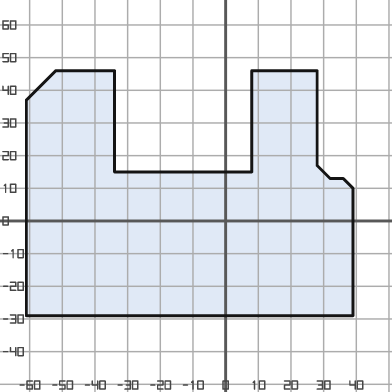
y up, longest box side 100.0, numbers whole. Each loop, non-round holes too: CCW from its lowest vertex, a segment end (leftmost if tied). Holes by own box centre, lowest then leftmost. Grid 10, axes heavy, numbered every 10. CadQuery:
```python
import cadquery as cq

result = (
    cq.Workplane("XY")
    .moveTo(-61.0, -29.0)
    .lineTo(39.0, -29.0)
    .lineTo(39.0, 10.0)
    .lineTo(36.0, 13.0)
    .lineTo(32.0, 13.0)
    .lineTo(28.0, 17.0)
    .lineTo(28.0, 46.0)
    .lineTo(8.0, 46.0)
    .lineTo(8.0, 15.0)
    .lineTo(-34.0, 15.0)
    .lineTo(-34.0, 46.0)
    .lineTo(-52.0, 46.0)
    .lineTo(-61.0, 37.0)
    .close()
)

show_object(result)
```